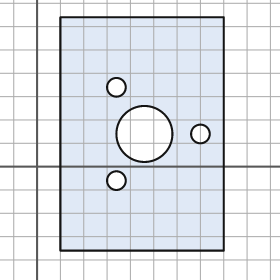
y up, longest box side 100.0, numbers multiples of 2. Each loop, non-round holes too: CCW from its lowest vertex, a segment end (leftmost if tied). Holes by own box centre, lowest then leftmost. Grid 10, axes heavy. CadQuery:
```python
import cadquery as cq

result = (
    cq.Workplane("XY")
    .moveTo(10.0, -36.0)
    .lineTo(80.0, -36.0)
    .lineTo(80.0, 64.0)
    .lineTo(10.0, 64.0)
    .close()
    .moveTo(34.0, -6.0)
    .circle(4.0)
    .moveTo(46.0, 14.0)
    .circle(12.0)
    .moveTo(70.0, 14.0)
    .circle(4.0)
    .moveTo(34.0, 34.0)
    .circle(4.0)
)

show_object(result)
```